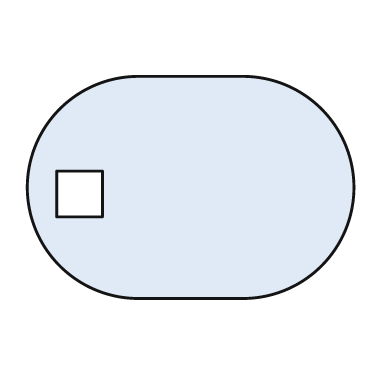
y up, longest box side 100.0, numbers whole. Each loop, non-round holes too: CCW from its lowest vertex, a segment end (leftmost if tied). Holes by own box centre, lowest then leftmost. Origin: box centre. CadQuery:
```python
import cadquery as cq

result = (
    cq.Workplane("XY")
    .moveTo(-16.0, -34.0)
    .lineTo(16.0, -34.0)
    .threePointArc((50.0, 0.0), (16.0, 34.0))
    .lineTo(-16.0, 34.0)
    .threePointArc((-50.0, 0.0), (-16.0, -34.0))
    .close()
    .moveTo(-41.0, -9.0)
    .lineTo(-27.0, -9.0)
    .lineTo(-27.0, 5.0)
    .lineTo(-41.0, 5.0)
    .close()
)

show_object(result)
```